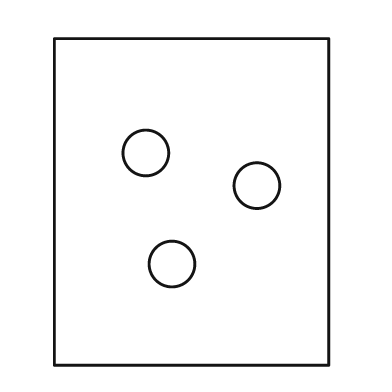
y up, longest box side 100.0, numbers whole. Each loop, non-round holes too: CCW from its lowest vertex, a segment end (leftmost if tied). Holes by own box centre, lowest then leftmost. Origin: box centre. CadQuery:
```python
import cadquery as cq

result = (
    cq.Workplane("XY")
    .moveTo(-42.0, -50.0)
    .lineTo(42.0, -50.0)
    .lineTo(42.0, 50.0)
    .lineTo(-42.0, 50.0)
    .close()
    .moveTo(-6.0, -19.0)
    .circle(7.0)
    .moveTo(20.0, 5.0)
    .circle(7.0)
    .moveTo(-14.0, 15.0)
    .circle(7.0)
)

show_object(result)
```